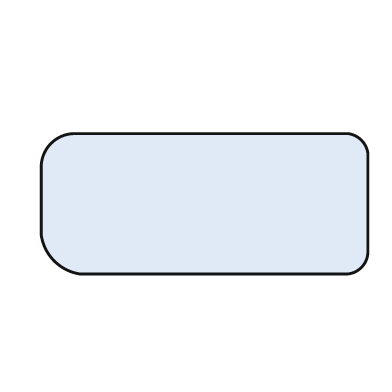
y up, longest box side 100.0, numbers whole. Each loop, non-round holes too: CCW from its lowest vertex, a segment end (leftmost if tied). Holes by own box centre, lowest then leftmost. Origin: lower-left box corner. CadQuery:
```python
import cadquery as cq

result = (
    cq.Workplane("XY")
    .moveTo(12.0, 0.0)
    .lineTo(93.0, 0.0)
    .threePointArc((98.0, 2.0), (100.0, 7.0))
    .lineTo(100.0, 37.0)
    .threePointArc((98.0, 41.0), (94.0, 43.0))
    .lineTo(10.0, 43.0)
    .threePointArc((3.0, 40.0), (0.0, 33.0))
    .lineTo(0.0, 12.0)
    .threePointArc((4.0, 4.0), (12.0, 0.0))
    .close()
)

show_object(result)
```